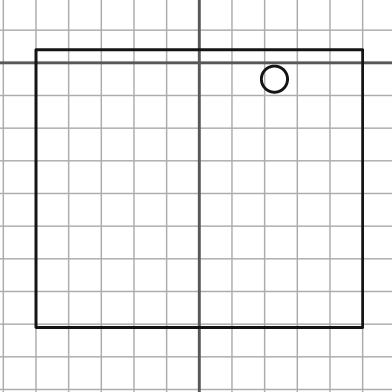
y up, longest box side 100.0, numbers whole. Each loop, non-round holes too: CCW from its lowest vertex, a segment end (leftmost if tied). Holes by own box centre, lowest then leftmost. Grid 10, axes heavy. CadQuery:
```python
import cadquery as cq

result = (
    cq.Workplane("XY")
    .moveTo(-50.0, -81.0)
    .lineTo(50.0, -81.0)
    .lineTo(50.0, 4.0)
    .lineTo(-50.0, 4.0)
    .close()
    .moveTo(23.0, -5.0)
    .circle(4.0)
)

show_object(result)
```